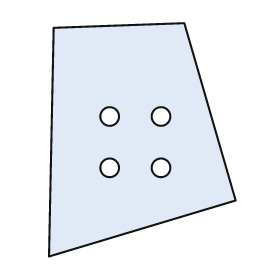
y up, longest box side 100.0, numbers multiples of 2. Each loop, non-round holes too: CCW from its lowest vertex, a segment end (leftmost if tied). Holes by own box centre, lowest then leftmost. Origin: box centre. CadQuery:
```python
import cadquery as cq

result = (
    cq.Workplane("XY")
    .moveTo(-40.0, -50.0)
    .lineTo(40.0, -26.0)
    .lineTo(18.0, 50.0)
    .lineTo(-38.0, 48.0)
    .close()
    .moveTo(-14.0, -12.0)
    .circle(4.0)
    .moveTo(8.0, -12.0)
    .circle(4.0)
    .moveTo(-14.0, 10.0)
    .circle(4.0)
    .moveTo(8.0, 10.0)
    .circle(4.0)
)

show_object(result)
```